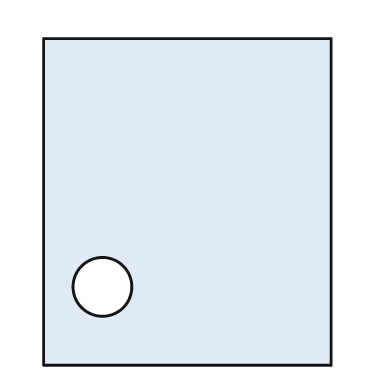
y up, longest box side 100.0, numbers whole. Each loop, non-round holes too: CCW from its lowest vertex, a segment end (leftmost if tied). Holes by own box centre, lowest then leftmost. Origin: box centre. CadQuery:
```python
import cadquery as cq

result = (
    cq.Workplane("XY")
    .moveTo(-44.0, -50.0)
    .lineTo(44.0, -50.0)
    .lineTo(44.0, 50.0)
    .lineTo(-44.0, 50.0)
    .close()
    .moveTo(-26.0, -26.0)
    .circle(9.0)
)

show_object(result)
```